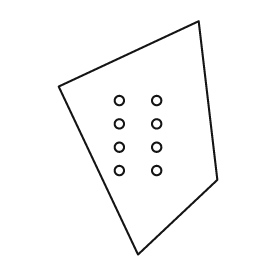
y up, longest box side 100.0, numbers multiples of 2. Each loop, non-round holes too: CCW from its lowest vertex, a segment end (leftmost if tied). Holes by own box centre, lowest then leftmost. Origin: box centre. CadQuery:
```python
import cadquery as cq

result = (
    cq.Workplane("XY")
    .moveTo(0.0, -50.0)
    .lineTo(34.0, -18.0)
    .lineTo(26.0, 50.0)
    .lineTo(-34.0, 22.0)
    .close()
    .moveTo(-8.0, -14.0)
    .circle(2.0)
    .moveTo(8.0, -14.0)
    .circle(2.0)
    .moveTo(-8.0, -4.0)
    .circle(2.0)
    .moveTo(8.0, -4.0)
    .circle(2.0)
    .moveTo(-8.0, 6.0)
    .circle(2.0)
    .moveTo(8.0, 6.0)
    .circle(2.0)
    .moveTo(-8.0, 16.0)
    .circle(2.0)
    .moveTo(8.0, 16.0)
    .circle(2.0)
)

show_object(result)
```